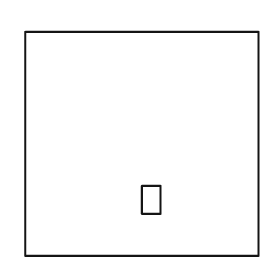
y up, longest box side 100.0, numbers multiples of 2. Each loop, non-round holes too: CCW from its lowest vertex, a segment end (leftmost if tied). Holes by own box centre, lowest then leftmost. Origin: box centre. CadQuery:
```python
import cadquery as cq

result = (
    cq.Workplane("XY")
    .moveTo(-50.0, -48.0)
    .lineTo(50.0, -48.0)
    .lineTo(50.0, 48.0)
    .lineTo(-50.0, 48.0)
    .close()
    .moveTo(0.0, -30.0)
    .lineTo(8.0, -30.0)
    .lineTo(8.0, -18.0)
    .lineTo(0.0, -18.0)
    .close()
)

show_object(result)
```